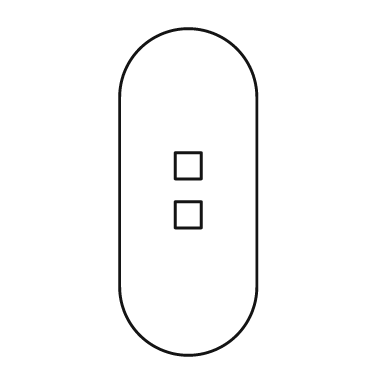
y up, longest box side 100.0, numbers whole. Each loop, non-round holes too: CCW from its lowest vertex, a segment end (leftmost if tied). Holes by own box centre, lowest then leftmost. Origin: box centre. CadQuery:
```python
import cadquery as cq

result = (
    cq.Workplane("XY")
    .moveTo(-21.0, -29.0)
    .threePointArc((0.0, -50.0), (21.0, -29.0))
    .lineTo(21.0, 29.0)
    .threePointArc((0.0, 50.0), (-21.0, 29.0))
    .close()
    .moveTo(-4.0, -11.0)
    .lineTo(4.0, -11.0)
    .lineTo(4.0, -3.0)
    .lineTo(-4.0, -3.0)
    .close()
    .moveTo(-4.0, 4.0)
    .lineTo(4.0, 4.0)
    .lineTo(4.0, 12.0)
    .lineTo(-4.0, 12.0)
    .close()
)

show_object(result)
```